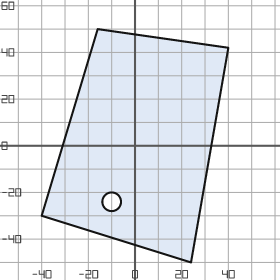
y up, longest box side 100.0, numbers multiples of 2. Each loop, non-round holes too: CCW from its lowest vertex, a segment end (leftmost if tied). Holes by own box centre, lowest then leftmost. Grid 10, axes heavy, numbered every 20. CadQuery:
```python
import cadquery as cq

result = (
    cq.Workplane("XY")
    .moveTo(24.0, -50.0)
    .lineTo(40.0, 42.0)
    .lineTo(-16.0, 50.0)
    .lineTo(-40.0, -30.0)
    .close()
    .moveTo(-10.0, -24.0)
    .circle(4.0)
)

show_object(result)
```